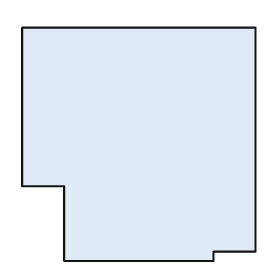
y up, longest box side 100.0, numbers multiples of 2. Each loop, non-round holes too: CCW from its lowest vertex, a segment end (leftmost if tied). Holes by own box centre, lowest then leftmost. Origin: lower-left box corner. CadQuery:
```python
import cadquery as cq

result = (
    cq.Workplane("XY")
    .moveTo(18.0, 0.0)
    .lineTo(82.0, 0.0)
    .lineTo(82.0, 4.0)
    .lineTo(100.0, 4.0)
    .lineTo(100.0, 100.0)
    .lineTo(0.0, 100.0)
    .lineTo(0.0, 32.0)
    .lineTo(18.0, 32.0)
    .close()
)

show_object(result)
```